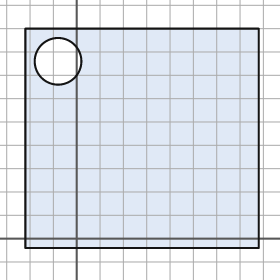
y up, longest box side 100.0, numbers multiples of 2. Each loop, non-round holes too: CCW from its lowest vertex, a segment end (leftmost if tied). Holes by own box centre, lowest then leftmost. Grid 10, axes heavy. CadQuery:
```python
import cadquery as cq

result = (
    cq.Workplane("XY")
    .moveTo(-22.0, -4.0)
    .lineTo(78.0, -4.0)
    .lineTo(78.0, 90.0)
    .lineTo(-22.0, 90.0)
    .close()
    .moveTo(-8.0, 76.0)
    .circle(10.0)
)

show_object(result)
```